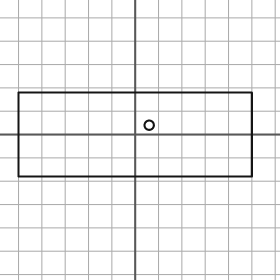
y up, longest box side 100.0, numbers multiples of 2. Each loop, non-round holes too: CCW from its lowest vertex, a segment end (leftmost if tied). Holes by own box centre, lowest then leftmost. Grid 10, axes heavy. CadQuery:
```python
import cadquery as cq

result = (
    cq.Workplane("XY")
    .moveTo(-50.0, -18.0)
    .lineTo(50.0, -18.0)
    .lineTo(50.0, 18.0)
    .lineTo(-50.0, 18.0)
    .close()
    .moveTo(6.0, 4.0)
    .circle(2.0)
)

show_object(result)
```